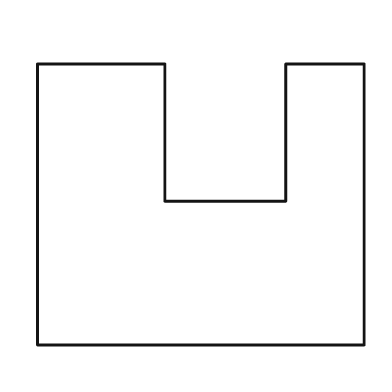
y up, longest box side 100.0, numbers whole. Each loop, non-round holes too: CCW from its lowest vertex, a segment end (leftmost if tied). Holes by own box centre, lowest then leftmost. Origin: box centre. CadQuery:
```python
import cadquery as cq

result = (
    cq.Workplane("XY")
    .moveTo(-50.0, -43.0)
    .lineTo(50.0, -43.0)
    .lineTo(50.0, 43.0)
    .lineTo(26.0, 43.0)
    .lineTo(26.0, 1.0)
    .lineTo(-11.0, 1.0)
    .lineTo(-11.0, 43.0)
    .lineTo(-50.0, 43.0)
    .close()
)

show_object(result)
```